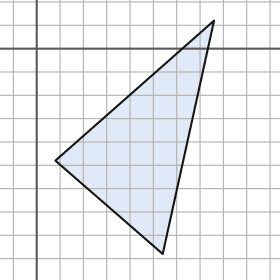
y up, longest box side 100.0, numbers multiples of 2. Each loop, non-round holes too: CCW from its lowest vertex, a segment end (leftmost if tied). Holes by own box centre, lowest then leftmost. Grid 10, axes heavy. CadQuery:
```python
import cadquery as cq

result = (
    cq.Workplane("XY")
    .moveTo(54.0, -88.0)
    .lineTo(76.0, 12.0)
    .lineTo(8.0, -48.0)
    .close()
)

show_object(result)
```